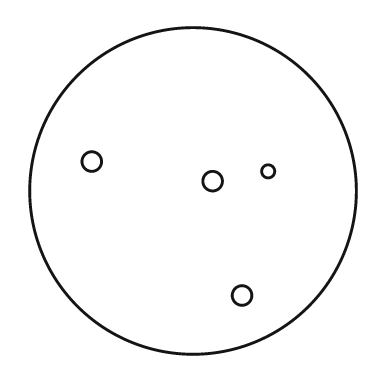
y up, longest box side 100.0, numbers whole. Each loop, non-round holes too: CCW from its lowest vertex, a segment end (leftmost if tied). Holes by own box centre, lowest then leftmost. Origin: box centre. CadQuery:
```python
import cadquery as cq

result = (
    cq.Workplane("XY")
    .moveTo(0.0, 0.0)
    .circle(50.0)
    .moveTo(15.0, -32.0)
    .circle(3.0)
    .moveTo(6.0, 3.0)
    .circle(3.0)
    .moveTo(23.0, 6.0)
    .circle(2.0)
    .moveTo(-31.0, 9.0)
    .circle(3.0)
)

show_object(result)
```